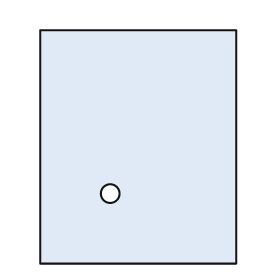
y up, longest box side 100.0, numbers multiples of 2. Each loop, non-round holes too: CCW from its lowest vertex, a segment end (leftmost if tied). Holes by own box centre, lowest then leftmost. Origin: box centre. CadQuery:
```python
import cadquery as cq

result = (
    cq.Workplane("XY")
    .moveTo(-42.0, -50.0)
    .lineTo(42.0, -50.0)
    .lineTo(42.0, 50.0)
    .lineTo(-42.0, 50.0)
    .close()
    .moveTo(-12.0, -20.0)
    .circle(4.0)
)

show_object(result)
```